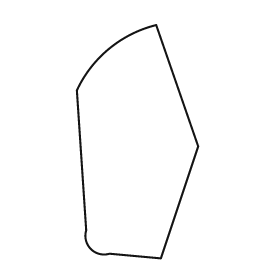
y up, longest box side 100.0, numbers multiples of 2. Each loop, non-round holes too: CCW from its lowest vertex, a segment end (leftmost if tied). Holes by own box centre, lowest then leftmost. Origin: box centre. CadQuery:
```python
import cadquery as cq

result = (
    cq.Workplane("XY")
    .moveTo(10.0, -50.0)
    .lineTo(26.0, -2.0)
    .lineTo(8.0, 50.0)
    .threePointArc((-12.0, 40.0), (-26.0, 22.0))
    .lineTo(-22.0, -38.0)
    .threePointArc((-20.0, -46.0), (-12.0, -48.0))
    .close()
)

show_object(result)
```